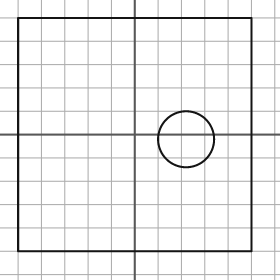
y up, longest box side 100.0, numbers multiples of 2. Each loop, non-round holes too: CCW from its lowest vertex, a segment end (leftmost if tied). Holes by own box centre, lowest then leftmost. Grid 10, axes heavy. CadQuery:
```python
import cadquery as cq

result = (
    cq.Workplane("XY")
    .moveTo(-50.0, -50.0)
    .lineTo(50.0, -50.0)
    .lineTo(50.0, 50.0)
    .lineTo(-50.0, 50.0)
    .close()
    .moveTo(22.0, -2.0)
    .circle(12.0)
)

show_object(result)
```